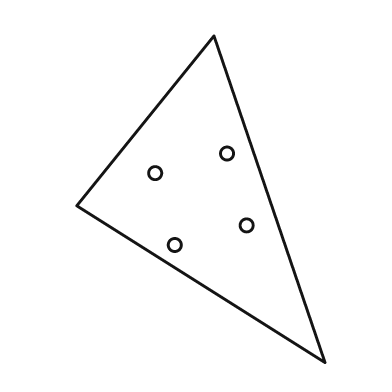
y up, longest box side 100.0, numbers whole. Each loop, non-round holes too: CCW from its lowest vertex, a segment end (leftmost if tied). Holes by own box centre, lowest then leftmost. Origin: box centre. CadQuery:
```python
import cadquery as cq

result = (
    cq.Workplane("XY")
    .moveTo(38.0, -50.0)
    .lineTo(4.0, 50.0)
    .lineTo(-38.0, -2.0)
    .close()
    .moveTo(-8.0, -14.0)
    .circle(2.0)
    .moveTo(14.0, -8.0)
    .circle(2.0)
    .moveTo(-14.0, 8.0)
    .circle(2.0)
    .moveTo(8.0, 14.0)
    .circle(2.0)
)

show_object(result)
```